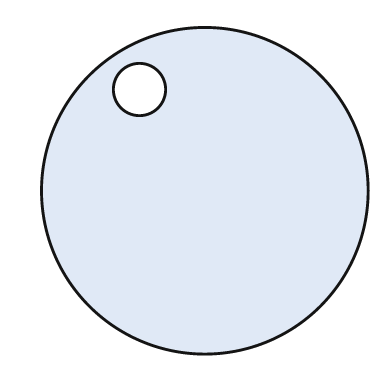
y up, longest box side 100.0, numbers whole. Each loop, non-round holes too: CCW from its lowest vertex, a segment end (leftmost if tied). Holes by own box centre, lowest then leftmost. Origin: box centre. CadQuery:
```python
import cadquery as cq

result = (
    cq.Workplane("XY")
    .moveTo(0.0, 0.0)
    .circle(50.0)
    .moveTo(-20.0, 31.0)
    .circle(8.0)
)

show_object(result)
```